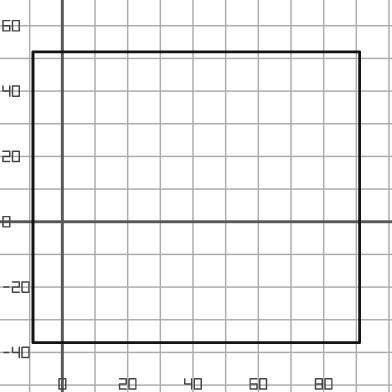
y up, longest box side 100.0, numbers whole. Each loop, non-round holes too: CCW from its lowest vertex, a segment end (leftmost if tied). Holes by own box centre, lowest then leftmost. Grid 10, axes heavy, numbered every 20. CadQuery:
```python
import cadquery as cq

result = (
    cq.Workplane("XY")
    .moveTo(-9.0, -37.0)
    .lineTo(91.0, -37.0)
    .lineTo(91.0, 52.0)
    .lineTo(-9.0, 52.0)
    .close()
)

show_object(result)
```